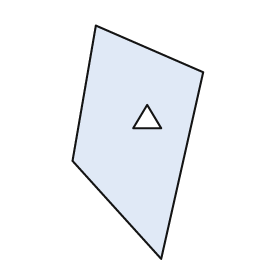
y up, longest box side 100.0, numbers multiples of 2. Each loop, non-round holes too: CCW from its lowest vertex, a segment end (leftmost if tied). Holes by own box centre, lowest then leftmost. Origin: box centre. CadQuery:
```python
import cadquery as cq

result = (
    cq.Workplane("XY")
    .moveTo(10.0, -50.0)
    .lineTo(28.0, 30.0)
    .lineTo(-18.0, 50.0)
    .lineTo(-28.0, -8.0)
    .close()
    .moveTo(-2.0, 6.0)
    .lineTo(10.0, 6.0)
    .lineTo(4.0, 16.0)
    .close()
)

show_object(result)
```